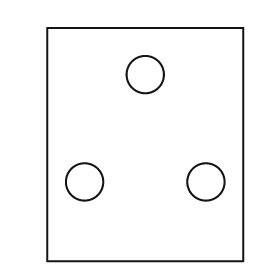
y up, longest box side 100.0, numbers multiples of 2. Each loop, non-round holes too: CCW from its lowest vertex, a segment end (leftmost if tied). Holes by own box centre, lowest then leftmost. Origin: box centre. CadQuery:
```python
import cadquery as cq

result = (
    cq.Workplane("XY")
    .moveTo(-42.0, -50.0)
    .lineTo(42.0, -50.0)
    .lineTo(42.0, 50.0)
    .lineTo(-42.0, 50.0)
    .close()
    .moveTo(-26.0, -16.0)
    .circle(8.0)
    .moveTo(26.0, -16.0)
    .circle(8.0)
    .moveTo(0.0, 30.0)
    .circle(8.0)
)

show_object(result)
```